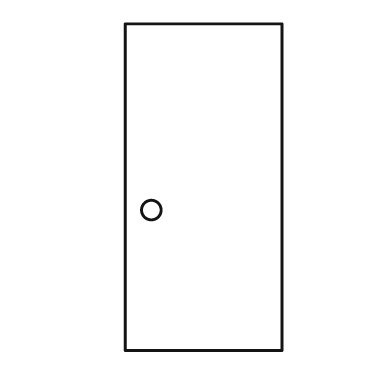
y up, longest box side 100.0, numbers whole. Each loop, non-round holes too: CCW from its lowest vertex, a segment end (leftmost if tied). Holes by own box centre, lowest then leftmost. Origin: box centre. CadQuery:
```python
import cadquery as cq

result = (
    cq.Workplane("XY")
    .moveTo(-24.0, -50.0)
    .lineTo(24.0, -50.0)
    .lineTo(24.0, 50.0)
    .lineTo(-24.0, 50.0)
    .close()
    .moveTo(-16.0, -7.0)
    .circle(3.0)
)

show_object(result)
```